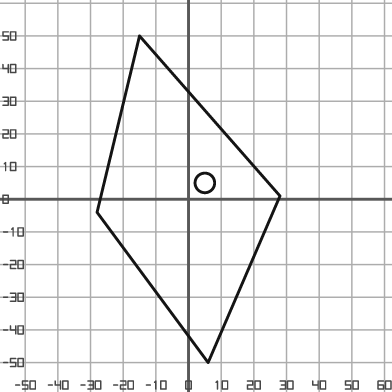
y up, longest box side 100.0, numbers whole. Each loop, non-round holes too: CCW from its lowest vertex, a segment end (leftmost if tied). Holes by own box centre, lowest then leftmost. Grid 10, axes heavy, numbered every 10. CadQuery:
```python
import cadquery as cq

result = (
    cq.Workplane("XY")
    .moveTo(6.0, -50.0)
    .lineTo(28.0, 1.0)
    .lineTo(-15.0, 50.0)
    .lineTo(-28.0, -4.0)
    .close()
    .moveTo(5.0, 5.0)
    .circle(3.0)
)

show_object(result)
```